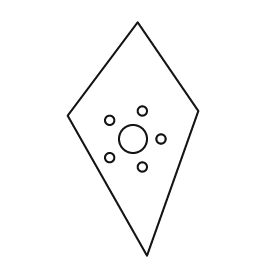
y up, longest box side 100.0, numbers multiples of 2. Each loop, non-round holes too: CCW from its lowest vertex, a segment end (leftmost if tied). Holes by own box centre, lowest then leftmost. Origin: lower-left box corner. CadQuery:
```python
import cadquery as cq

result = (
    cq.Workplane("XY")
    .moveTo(34.0, 0.0)
    .lineTo(56.0, 62.0)
    .lineTo(30.0, 100.0)
    .lineTo(0.0, 60.0)
    .close()
    .moveTo(32.0, 38.0)
    .circle(2.0)
    .moveTo(18.0, 42.0)
    .circle(2.0)
    .moveTo(28.0, 50.0)
    .circle(6.0)
    .moveTo(40.0, 50.0)
    .circle(2.0)
    .moveTo(18.0, 58.0)
    .circle(2.0)
    .moveTo(32.0, 62.0)
    .circle(2.0)
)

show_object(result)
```